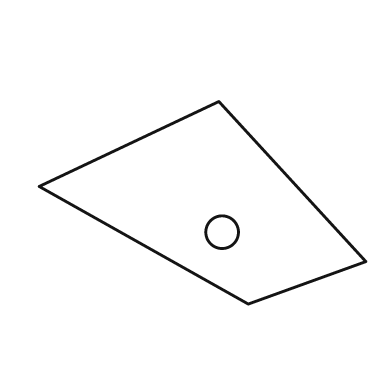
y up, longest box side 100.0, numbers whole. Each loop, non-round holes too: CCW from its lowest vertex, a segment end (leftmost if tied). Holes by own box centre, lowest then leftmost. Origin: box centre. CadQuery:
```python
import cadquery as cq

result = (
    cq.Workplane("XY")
    .moveTo(14.0, -31.0)
    .lineTo(50.0, -18.0)
    .lineTo(5.0, 31.0)
    .lineTo(-50.0, 5.0)
    .close()
    .moveTo(6.0, -9.0)
    .circle(5.0)
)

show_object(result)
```